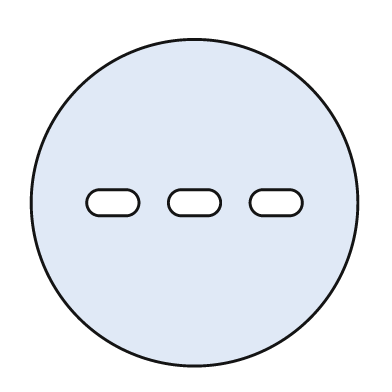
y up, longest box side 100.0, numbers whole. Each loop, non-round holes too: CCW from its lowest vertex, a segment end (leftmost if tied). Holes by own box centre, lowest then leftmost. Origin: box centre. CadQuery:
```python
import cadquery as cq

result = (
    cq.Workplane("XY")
    .moveTo(0.0, 0.0)
    .circle(50.0)
    .moveTo(-29.0, -4.0)
    .lineTo(-21.0, -4.0)
    .threePointArc((-17.0, 0.0), (-21.0, 4.0))
    .lineTo(-29.0, 4.0)
    .threePointArc((-33.0, 0.0), (-29.0, -4.0))
    .close()
    .moveTo(-4.0, -4.0)
    .lineTo(4.0, -4.0)
    .threePointArc((8.0, 0.0), (4.0, 4.0))
    .lineTo(-4.0, 4.0)
    .threePointArc((-8.0, 0.0), (-4.0, -4.0))
    .close()
    .moveTo(21.0, -4.0)
    .lineTo(29.0, -4.0)
    .threePointArc((33.0, 0.0), (29.0, 4.0))
    .lineTo(21.0, 4.0)
    .threePointArc((17.0, 0.0), (21.0, -4.0))
    .close()
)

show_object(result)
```